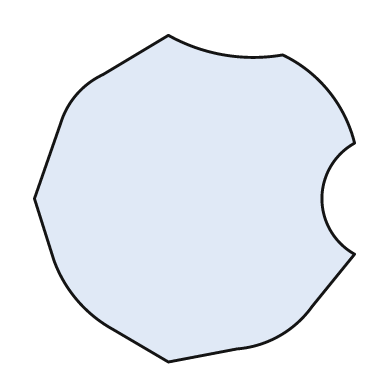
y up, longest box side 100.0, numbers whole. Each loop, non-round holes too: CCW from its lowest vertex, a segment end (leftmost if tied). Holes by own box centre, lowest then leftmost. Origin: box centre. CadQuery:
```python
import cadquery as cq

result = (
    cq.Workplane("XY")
    .moveTo(-8.0, -50.0)
    .lineTo(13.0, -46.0)
    .threePointArc((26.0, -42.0), (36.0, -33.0))
    .lineTo(49.0, -17.0)
    .threePointArc((39.0, 0.0), (49.0, 17.0))
    .threePointArc((41.0, 33.0), (27.0, 44.0))
    .threePointArc((9.0, 44.0), (-8.0, 50.0))
    .lineTo(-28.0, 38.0)
    .threePointArc((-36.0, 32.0), (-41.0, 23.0))
    .lineTo(-49.0, 0.0)
    .lineTo(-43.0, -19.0)
    .threePointArc((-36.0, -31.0), (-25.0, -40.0))
    .close()
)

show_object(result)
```